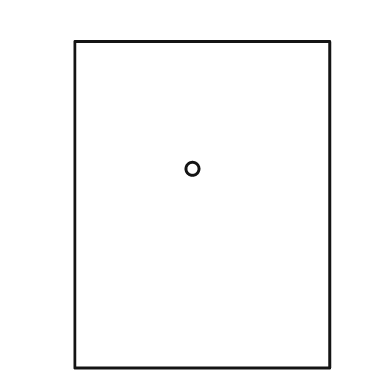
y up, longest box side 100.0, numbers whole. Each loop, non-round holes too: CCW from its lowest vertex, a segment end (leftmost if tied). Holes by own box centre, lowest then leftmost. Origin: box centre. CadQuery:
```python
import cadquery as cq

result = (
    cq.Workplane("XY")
    .moveTo(-39.0, -50.0)
    .lineTo(39.0, -50.0)
    .lineTo(39.0, 50.0)
    .lineTo(-39.0, 50.0)
    .close()
    .moveTo(-3.0, 11.0)
    .circle(2.0)
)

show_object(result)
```